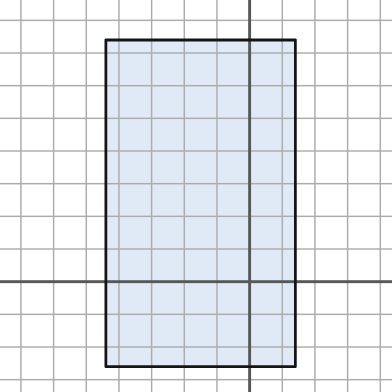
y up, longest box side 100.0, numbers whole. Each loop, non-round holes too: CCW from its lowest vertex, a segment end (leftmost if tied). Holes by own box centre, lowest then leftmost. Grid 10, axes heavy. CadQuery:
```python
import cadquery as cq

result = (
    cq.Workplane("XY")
    .moveTo(-44.0, -26.0)
    .lineTo(14.0, -26.0)
    .lineTo(14.0, 74.0)
    .lineTo(-44.0, 74.0)
    .close()
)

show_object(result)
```